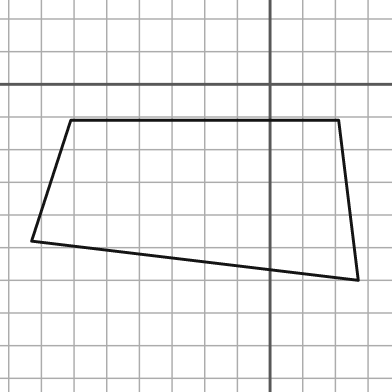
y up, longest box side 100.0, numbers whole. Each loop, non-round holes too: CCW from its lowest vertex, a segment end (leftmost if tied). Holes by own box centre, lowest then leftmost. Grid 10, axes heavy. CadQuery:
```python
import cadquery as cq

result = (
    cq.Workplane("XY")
    .moveTo(27.0, -60.0)
    .lineTo(21.0, -11.0)
    .lineTo(-61.0, -11.0)
    .lineTo(-73.0, -48.0)
    .close()
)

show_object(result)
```